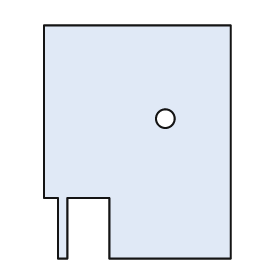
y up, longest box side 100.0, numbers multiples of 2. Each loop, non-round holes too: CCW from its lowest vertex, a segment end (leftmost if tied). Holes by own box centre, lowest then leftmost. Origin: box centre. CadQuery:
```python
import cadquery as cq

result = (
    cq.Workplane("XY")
    .moveTo(-34.0, -50.0)
    .lineTo(-30.0, -50.0)
    .lineTo(-30.0, -24.0)
    .lineTo(-12.0, -24.0)
    .lineTo(-12.0, -50.0)
    .lineTo(40.0, -50.0)
    .lineTo(40.0, 50.0)
    .lineTo(-40.0, 50.0)
    .lineTo(-40.0, -24.0)
    .lineTo(-34.0, -24.0)
    .close()
    .moveTo(12.0, 10.0)
    .circle(4.0)
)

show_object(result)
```